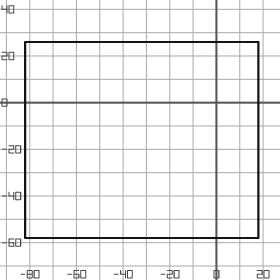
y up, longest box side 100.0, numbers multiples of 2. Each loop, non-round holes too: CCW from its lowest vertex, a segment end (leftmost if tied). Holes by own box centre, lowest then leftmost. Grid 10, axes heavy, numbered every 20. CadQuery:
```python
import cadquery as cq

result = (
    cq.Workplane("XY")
    .moveTo(-82.0, -58.0)
    .lineTo(18.0, -58.0)
    .lineTo(18.0, 26.0)
    .lineTo(-82.0, 26.0)
    .close()
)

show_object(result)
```